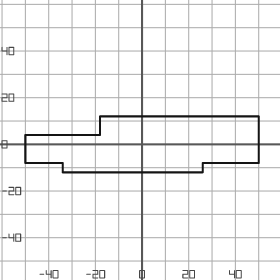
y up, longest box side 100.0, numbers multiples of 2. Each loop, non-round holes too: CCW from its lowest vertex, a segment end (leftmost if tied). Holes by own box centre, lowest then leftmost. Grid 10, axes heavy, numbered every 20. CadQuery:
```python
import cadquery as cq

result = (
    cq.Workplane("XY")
    .moveTo(-34.0, -12.0)
    .lineTo(26.0, -12.0)
    .lineTo(26.0, -8.0)
    .lineTo(50.0, -8.0)
    .lineTo(50.0, 12.0)
    .lineTo(-18.0, 12.0)
    .lineTo(-18.0, 4.0)
    .lineTo(-50.0, 4.0)
    .lineTo(-50.0, -8.0)
    .lineTo(-34.0, -8.0)
    .close()
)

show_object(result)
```